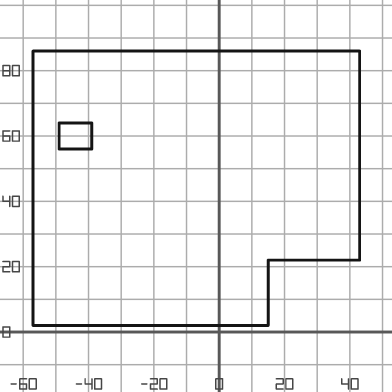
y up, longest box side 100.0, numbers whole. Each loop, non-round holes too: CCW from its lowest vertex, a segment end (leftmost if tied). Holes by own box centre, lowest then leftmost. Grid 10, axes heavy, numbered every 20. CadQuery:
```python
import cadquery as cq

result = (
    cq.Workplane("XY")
    .moveTo(-57.0, 2.0)
    .lineTo(15.0, 2.0)
    .lineTo(15.0, 22.0)
    .lineTo(43.0, 22.0)
    .lineTo(43.0, 86.0)
    .lineTo(-57.0, 86.0)
    .close()
    .moveTo(-49.0, 56.0)
    .lineTo(-39.0, 56.0)
    .lineTo(-39.0, 64.0)
    .lineTo(-49.0, 64.0)
    .close()
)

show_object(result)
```